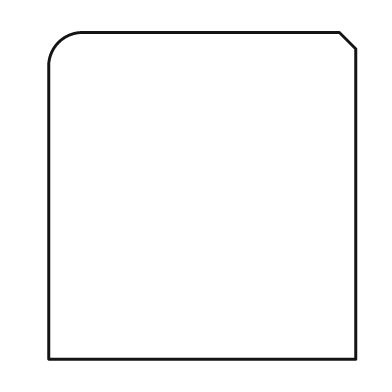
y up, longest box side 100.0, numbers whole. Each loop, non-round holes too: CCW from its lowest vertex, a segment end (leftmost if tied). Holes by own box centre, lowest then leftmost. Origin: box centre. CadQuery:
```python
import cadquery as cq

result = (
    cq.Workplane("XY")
    .moveTo(-47.0, -50.0)
    .lineTo(47.0, -50.0)
    .lineTo(47.0, 45.0)
    .lineTo(42.0, 50.0)
    .lineTo(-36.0, 50.0)
    .threePointArc((-44.0, 47.0), (-47.0, 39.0))
    .close()
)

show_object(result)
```